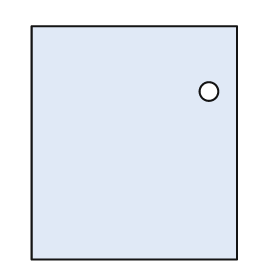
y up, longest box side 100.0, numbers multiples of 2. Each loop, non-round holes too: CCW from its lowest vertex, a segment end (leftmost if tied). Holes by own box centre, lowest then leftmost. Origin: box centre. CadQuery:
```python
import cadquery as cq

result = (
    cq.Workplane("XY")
    .moveTo(-44.0, -50.0)
    .lineTo(44.0, -50.0)
    .lineTo(44.0, 50.0)
    .lineTo(-44.0, 50.0)
    .close()
    .moveTo(32.0, 22.0)
    .circle(4.0)
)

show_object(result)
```